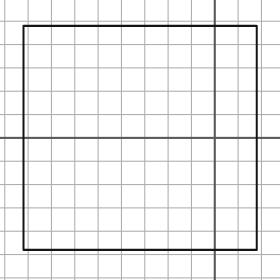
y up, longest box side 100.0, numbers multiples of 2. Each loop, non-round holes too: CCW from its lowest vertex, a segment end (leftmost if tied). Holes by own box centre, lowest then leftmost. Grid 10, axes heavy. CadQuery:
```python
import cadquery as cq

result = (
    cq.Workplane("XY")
    .moveTo(-82.0, -48.0)
    .lineTo(18.0, -48.0)
    .lineTo(18.0, 48.0)
    .lineTo(-82.0, 48.0)
    .close()
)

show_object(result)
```